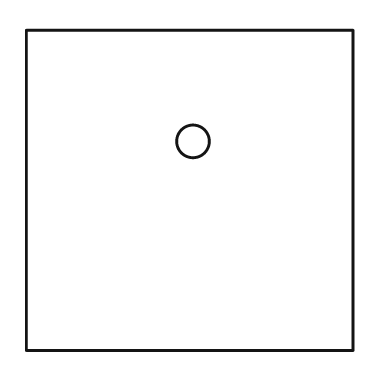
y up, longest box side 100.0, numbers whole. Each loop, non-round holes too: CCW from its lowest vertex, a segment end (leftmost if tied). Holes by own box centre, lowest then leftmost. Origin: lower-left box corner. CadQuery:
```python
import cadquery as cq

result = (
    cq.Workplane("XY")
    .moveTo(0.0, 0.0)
    .lineTo(100.0, 0.0)
    .lineTo(100.0, 98.0)
    .lineTo(0.0, 98.0)
    .close()
    .moveTo(51.0, 64.0)
    .circle(5.0)
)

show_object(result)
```